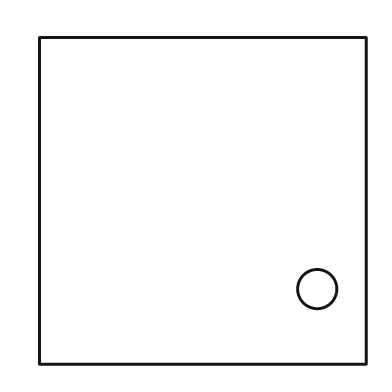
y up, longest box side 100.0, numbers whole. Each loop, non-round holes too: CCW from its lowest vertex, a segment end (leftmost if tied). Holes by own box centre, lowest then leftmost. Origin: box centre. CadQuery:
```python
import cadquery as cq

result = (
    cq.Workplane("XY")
    .moveTo(-50.0, -50.0)
    .lineTo(50.0, -50.0)
    .lineTo(50.0, 50.0)
    .lineTo(-50.0, 50.0)
    .close()
    .moveTo(35.0, -27.0)
    .circle(6.0)
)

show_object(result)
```